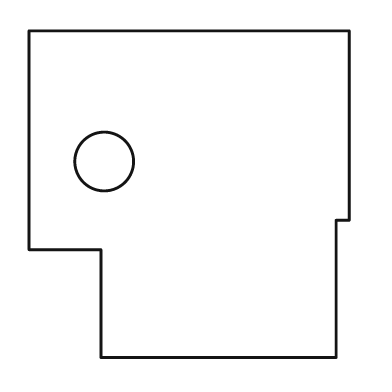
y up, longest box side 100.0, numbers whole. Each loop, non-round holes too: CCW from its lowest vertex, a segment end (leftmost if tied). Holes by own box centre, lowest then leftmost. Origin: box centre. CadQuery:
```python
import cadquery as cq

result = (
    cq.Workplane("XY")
    .moveTo(-27.0, -50.0)
    .lineTo(45.0, -50.0)
    .lineTo(45.0, -8.0)
    .lineTo(49.0, -8.0)
    .lineTo(49.0, 50.0)
    .lineTo(-49.0, 50.0)
    .lineTo(-49.0, -17.0)
    .lineTo(-27.0, -17.0)
    .close()
    .moveTo(-26.0, 10.0)
    .circle(9.0)
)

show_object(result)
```